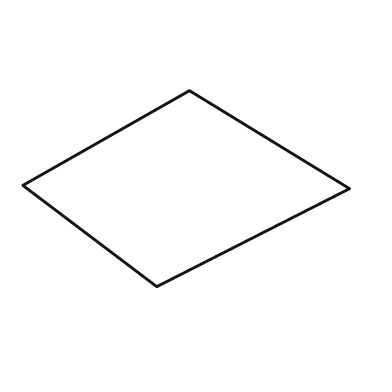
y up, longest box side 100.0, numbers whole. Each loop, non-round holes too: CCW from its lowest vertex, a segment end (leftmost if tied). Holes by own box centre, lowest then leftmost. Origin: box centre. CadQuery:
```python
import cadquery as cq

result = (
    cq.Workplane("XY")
    .moveTo(-9.0, -30.0)
    .lineTo(50.0, 0.0)
    .lineTo(1.0, 30.0)
    .lineTo(-50.0, 1.0)
    .close()
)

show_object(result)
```